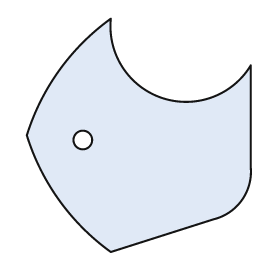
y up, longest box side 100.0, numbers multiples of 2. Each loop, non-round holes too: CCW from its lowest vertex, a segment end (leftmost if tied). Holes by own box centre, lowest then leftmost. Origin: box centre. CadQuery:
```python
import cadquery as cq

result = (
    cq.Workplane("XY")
    .moveTo(-12.0, -50.0)
    .lineTo(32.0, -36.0)
    .threePointArc((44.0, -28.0), (48.0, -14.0))
    .lineTo(48.0, 30.0)
    .threePointArc((10.0, 16.0), (-12.0, 50.0))
    .threePointArc((-34.0, 28.0), (-48.0, 0.0))
    .threePointArc((-34.0, -28.0), (-12.0, -50.0))
    .close()
    .moveTo(-24.0, -2.0)
    .circle(4.0)
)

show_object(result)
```